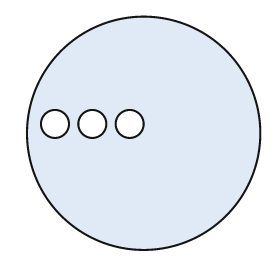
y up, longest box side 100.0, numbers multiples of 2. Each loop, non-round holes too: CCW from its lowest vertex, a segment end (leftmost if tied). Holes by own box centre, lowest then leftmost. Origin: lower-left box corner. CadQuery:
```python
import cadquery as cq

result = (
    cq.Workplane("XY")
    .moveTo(50.0, 50.0)
    .circle(50.0)
    .moveTo(12.0, 54.0)
    .circle(6.0)
    .moveTo(28.0, 54.0)
    .circle(6.0)
    .moveTo(44.0, 54.0)
    .circle(6.0)
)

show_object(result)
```